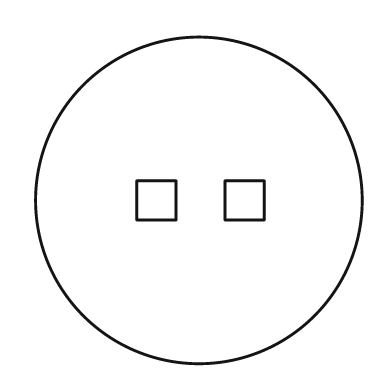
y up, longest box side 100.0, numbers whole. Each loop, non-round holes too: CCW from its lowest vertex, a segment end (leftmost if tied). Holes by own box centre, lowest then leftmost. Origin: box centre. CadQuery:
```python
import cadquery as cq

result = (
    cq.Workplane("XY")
    .moveTo(0.0, 0.0)
    .circle(50.0)
    .moveTo(-19.0, -6.0)
    .lineTo(-7.0, -6.0)
    .lineTo(-7.0, 6.0)
    .lineTo(-19.0, 6.0)
    .close()
    .moveTo(8.0, -6.0)
    .lineTo(20.0, -6.0)
    .lineTo(20.0, 6.0)
    .lineTo(8.0, 6.0)
    .close()
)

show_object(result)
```